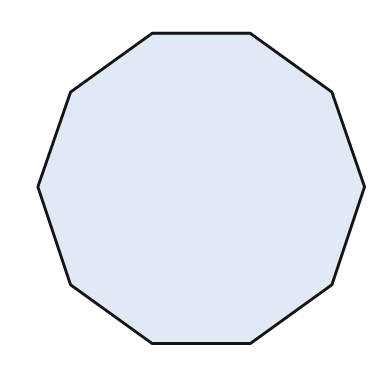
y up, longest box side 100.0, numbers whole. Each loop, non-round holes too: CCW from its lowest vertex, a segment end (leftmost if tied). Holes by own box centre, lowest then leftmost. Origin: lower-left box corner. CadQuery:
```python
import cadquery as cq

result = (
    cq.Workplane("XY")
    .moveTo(35.0, 0.0)
    .lineTo(65.0, 0.0)
    .lineTo(90.0, 18.0)
    .lineTo(100.0, 48.0)
    .lineTo(90.0, 77.0)
    .lineTo(65.0, 95.0)
    .lineTo(35.0, 95.0)
    .lineTo(10.0, 77.0)
    .lineTo(0.0, 48.0)
    .lineTo(10.0, 18.0)
    .close()
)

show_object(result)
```